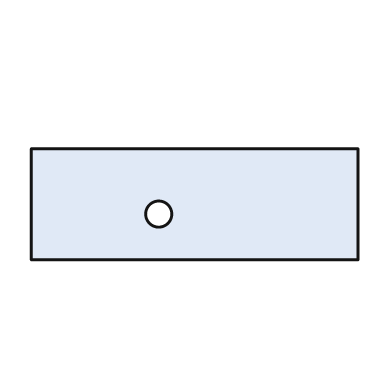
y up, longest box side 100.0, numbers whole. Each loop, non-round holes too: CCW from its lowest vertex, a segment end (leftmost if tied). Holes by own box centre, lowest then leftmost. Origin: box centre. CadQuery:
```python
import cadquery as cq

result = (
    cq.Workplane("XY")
    .moveTo(-50.0, -17.0)
    .lineTo(50.0, -17.0)
    .lineTo(50.0, 17.0)
    .lineTo(-50.0, 17.0)
    .close()
    .moveTo(-11.0, -3.0)
    .circle(4.0)
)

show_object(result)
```